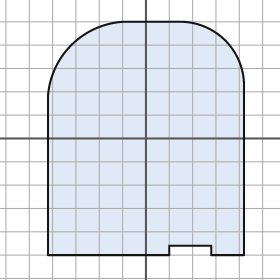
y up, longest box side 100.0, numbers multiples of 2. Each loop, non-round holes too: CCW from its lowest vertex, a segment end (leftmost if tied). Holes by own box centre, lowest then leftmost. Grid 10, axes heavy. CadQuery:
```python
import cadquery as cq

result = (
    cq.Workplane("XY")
    .moveTo(-42.0, -50.0)
    .lineTo(10.0, -50.0)
    .lineTo(10.0, -46.0)
    .lineTo(28.0, -46.0)
    .lineTo(28.0, -50.0)
    .lineTo(42.0, -50.0)
    .lineTo(42.0, 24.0)
    .threePointArc((34.0, 42.0), (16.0, 50.0))
    .lineTo(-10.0, 50.0)
    .threePointArc((-32.0, 40.0), (-42.0, 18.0))
    .close()
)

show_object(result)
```